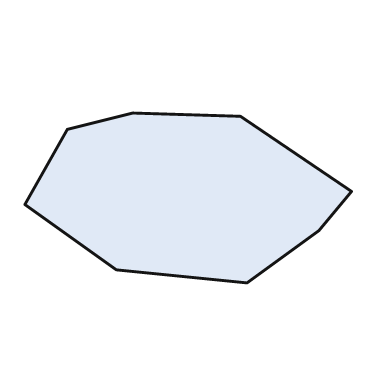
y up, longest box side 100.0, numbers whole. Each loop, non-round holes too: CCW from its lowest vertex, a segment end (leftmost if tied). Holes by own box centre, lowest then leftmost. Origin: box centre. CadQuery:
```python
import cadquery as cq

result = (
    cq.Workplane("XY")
    .moveTo(18.0, -26.0)
    .lineTo(40.0, -10.0)
    .lineTo(50.0, 2.0)
    .lineTo(16.0, 25.0)
    .lineTo(-17.0, 26.0)
    .lineTo(-37.0, 21.0)
    .lineTo(-50.0, -2.0)
    .lineTo(-22.0, -22.0)
    .close()
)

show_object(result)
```